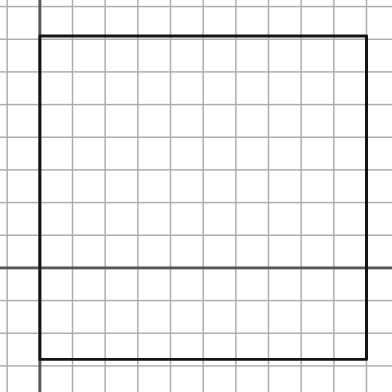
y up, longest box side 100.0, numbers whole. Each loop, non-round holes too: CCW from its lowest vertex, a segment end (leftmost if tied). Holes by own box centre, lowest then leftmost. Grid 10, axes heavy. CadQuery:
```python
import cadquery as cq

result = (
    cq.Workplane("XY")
    .moveTo(0.0, -28.0)
    .lineTo(100.0, -28.0)
    .lineTo(100.0, 71.0)
    .lineTo(0.0, 71.0)
    .close()
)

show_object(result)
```